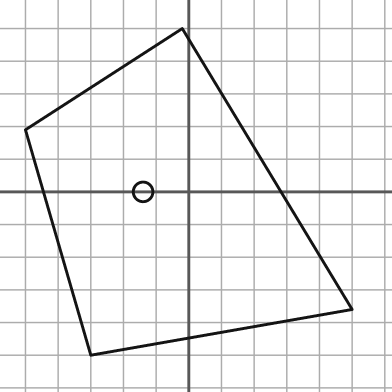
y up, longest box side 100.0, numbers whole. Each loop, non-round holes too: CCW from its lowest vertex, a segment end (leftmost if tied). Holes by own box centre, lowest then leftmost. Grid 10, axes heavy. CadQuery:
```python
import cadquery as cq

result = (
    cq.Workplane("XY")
    .moveTo(-30.0, -50.0)
    .lineTo(50.0, -36.0)
    .lineTo(-2.0, 50.0)
    .lineTo(-50.0, 19.0)
    .close()
    .moveTo(-14.0, 0.0)
    .circle(3.0)
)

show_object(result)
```